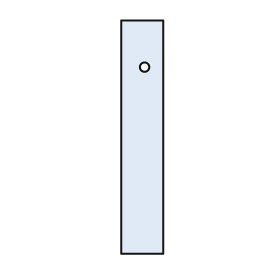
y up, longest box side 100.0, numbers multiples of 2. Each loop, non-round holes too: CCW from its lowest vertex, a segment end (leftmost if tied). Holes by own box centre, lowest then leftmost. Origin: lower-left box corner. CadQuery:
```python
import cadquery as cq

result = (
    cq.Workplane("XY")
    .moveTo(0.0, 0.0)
    .lineTo(18.0, 0.0)
    .lineTo(18.0, 100.0)
    .lineTo(0.0, 100.0)
    .close()
    .moveTo(10.0, 80.0)
    .circle(2.0)
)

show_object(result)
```